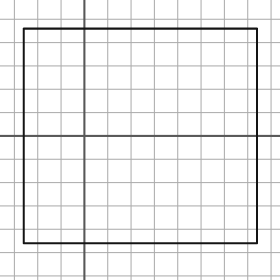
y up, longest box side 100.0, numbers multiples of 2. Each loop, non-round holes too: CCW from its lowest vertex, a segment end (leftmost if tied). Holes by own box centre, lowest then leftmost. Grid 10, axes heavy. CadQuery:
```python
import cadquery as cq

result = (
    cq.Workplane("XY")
    .moveTo(-26.0, -46.0)
    .lineTo(74.0, -46.0)
    .lineTo(74.0, 46.0)
    .lineTo(-26.0, 46.0)
    .close()
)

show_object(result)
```